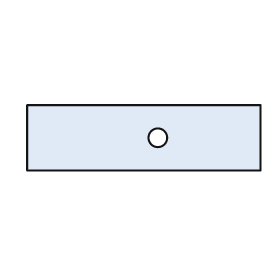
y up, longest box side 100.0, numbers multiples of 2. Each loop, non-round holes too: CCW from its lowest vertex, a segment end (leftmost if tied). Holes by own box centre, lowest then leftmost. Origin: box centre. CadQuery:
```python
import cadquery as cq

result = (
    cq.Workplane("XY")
    .moveTo(-50.0, -14.0)
    .lineTo(50.0, -14.0)
    .lineTo(50.0, 14.0)
    .lineTo(-50.0, 14.0)
    .close()
    .moveTo(6.0, 0.0)
    .circle(4.0)
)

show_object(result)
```